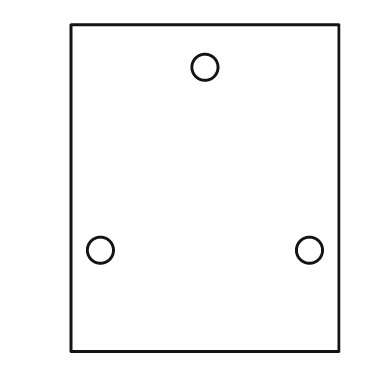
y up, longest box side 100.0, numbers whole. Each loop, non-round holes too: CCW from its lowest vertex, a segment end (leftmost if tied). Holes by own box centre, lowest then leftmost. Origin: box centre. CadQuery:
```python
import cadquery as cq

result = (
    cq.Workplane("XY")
    .moveTo(-41.0, -50.0)
    .lineTo(41.0, -50.0)
    .lineTo(41.0, 50.0)
    .lineTo(-41.0, 50.0)
    .close()
    .moveTo(-32.0, -19.0)
    .circle(4.0)
    .moveTo(32.0, -19.0)
    .circle(4.0)
    .moveTo(0.0, 37.0)
    .circle(4.0)
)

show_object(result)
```